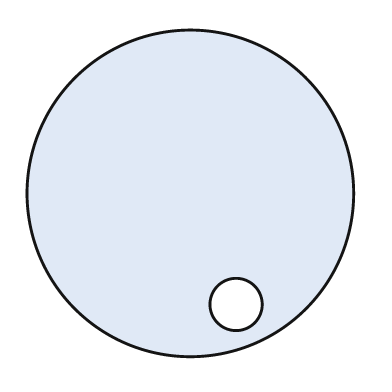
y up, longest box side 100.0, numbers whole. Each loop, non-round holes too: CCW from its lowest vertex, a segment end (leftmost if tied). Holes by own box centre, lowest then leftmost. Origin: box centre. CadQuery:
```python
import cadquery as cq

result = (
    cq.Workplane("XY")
    .moveTo(0.0, 0.0)
    .circle(50.0)
    .moveTo(14.0, -34.0)
    .circle(8.0)
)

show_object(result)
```